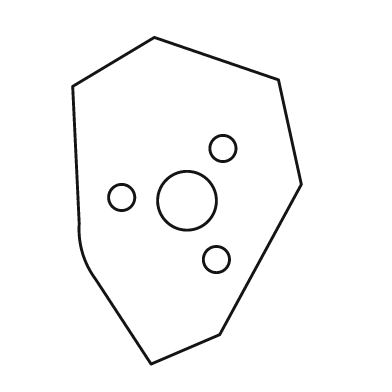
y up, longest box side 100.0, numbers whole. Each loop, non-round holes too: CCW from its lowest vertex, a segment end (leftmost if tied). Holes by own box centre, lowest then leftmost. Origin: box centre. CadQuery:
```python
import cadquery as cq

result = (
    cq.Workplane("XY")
    .moveTo(-11.0, -50.0)
    .lineTo(10.0, -41.0)
    .lineTo(35.0, 5.0)
    .lineTo(28.0, 37.0)
    .lineTo(-10.0, 50.0)
    .lineTo(-35.0, 35.0)
    .lineTo(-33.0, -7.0)
    .threePointArc((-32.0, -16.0), (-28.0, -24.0))
    .close()
    .moveTo(9.0, -18.0)
    .circle(4.0)
    .moveTo(0.0, 0.0)
    .circle(9.0)
    .moveTo(-20.0, 1.0)
    .circle(4.0)
    .moveTo(11.0, 16.0)
    .circle(4.0)
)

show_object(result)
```